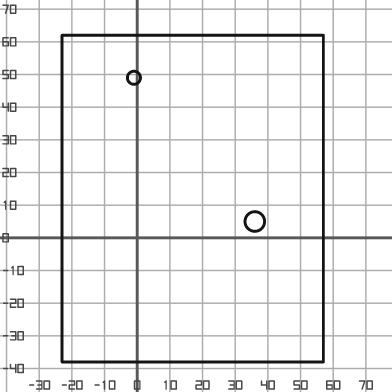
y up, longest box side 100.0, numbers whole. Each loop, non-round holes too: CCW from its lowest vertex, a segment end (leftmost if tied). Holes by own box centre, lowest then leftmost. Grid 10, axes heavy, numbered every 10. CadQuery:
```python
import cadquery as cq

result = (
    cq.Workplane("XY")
    .moveTo(-23.0, -38.0)
    .lineTo(57.0, -38.0)
    .lineTo(57.0, 62.0)
    .lineTo(-23.0, 62.0)
    .close()
    .moveTo(36.0, 5.0)
    .circle(3.0)
    .moveTo(-1.0, 49.0)
    .circle(2.0)
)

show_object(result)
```